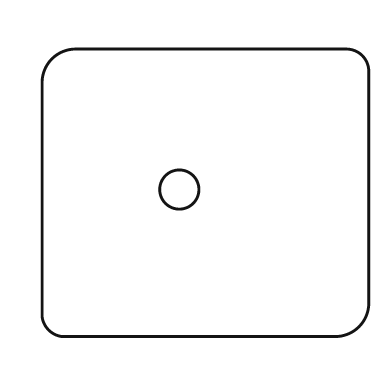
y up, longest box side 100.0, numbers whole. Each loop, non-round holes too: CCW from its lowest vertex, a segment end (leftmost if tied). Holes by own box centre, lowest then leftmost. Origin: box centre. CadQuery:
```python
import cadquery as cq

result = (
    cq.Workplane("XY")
    .moveTo(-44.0, -44.0)
    .lineTo(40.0, -44.0)
    .threePointArc((47.0, -41.0), (50.0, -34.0))
    .lineTo(50.0, 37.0)
    .threePointArc((48.0, 42.0), (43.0, 44.0))
    .lineTo(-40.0, 44.0)
    .threePointArc((-47.0, 41.0), (-50.0, 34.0))
    .lineTo(-50.0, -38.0)
    .threePointArc((-48.0, -42.0), (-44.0, -44.0))
    .close()
    .moveTo(-8.0, 1.0)
    .circle(6.0)
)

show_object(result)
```